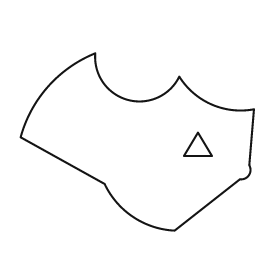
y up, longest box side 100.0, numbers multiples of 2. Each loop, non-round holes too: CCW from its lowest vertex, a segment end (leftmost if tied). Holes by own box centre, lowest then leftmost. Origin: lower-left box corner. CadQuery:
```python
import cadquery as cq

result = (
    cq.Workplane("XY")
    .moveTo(66.0, 0.0)
    .lineTo(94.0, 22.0)
    .threePointArc((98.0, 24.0), (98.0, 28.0))
    .lineTo(100.0, 52.0)
    .threePointArc((82.0, 54.0), (68.0, 66.0))
    .threePointArc((46.0, 56.0), (32.0, 76.0))
    .threePointArc((12.0, 62.0), (0.0, 40.0))
    .lineTo(36.0, 20.0)
    .threePointArc((48.0, 6.0), (66.0, 0.0))
    .close()
    .moveTo(70.0, 32.0)
    .lineTo(82.0, 32.0)
    .lineTo(76.0, 42.0)
    .close()
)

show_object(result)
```